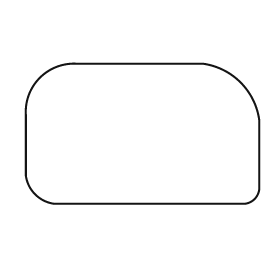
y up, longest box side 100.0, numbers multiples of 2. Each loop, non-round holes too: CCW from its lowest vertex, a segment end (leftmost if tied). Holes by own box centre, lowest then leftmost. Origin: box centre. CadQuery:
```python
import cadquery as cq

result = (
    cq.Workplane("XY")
    .moveTo(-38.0, -30.0)
    .lineTo(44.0, -30.0)
    .threePointArc((48.0, -28.0), (50.0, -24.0))
    .lineTo(50.0, 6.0)
    .threePointArc((42.0, 22.0), (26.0, 30.0))
    .lineTo(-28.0, 30.0)
    .threePointArc((-44.0, 24.0), (-50.0, 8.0))
    .lineTo(-50.0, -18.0)
    .threePointArc((-46.0, -26.0), (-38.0, -30.0))
    .close()
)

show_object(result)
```